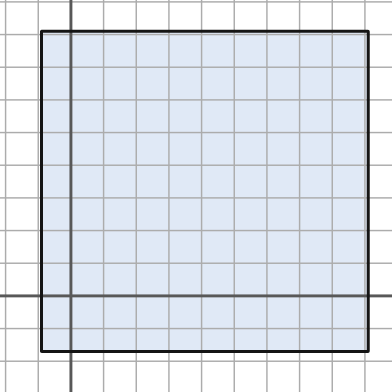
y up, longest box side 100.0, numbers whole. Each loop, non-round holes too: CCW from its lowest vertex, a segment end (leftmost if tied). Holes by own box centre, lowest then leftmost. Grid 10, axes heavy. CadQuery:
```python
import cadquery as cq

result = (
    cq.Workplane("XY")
    .moveTo(-9.0, -17.0)
    .lineTo(91.0, -17.0)
    .lineTo(91.0, 81.0)
    .lineTo(-9.0, 81.0)
    .close()
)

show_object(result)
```